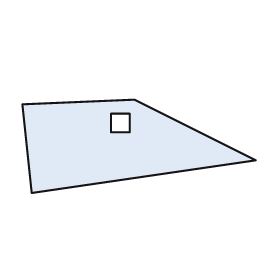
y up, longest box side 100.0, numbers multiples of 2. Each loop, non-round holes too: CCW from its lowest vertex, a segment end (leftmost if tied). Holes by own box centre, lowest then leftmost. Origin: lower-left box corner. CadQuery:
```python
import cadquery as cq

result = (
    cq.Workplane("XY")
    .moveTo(4.0, 0.0)
    .lineTo(100.0, 14.0)
    .lineTo(48.0, 40.0)
    .lineTo(0.0, 38.0)
    .close()
    .moveTo(38.0, 26.0)
    .lineTo(46.0, 26.0)
    .lineTo(46.0, 34.0)
    .lineTo(38.0, 34.0)
    .close()
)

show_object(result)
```